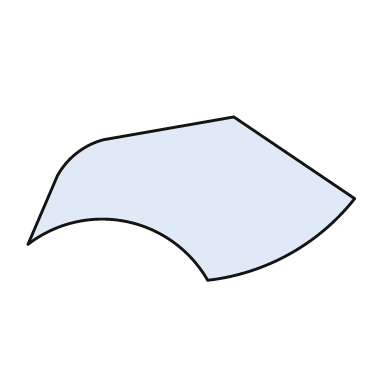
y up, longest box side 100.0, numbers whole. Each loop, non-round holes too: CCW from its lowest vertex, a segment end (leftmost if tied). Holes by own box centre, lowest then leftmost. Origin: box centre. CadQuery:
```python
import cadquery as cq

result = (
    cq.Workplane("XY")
    .moveTo(5.0, -25.0)
    .threePointArc((30.0, -17.0), (50.0, 0.0))
    .lineTo(13.0, 25.0)
    .lineTo(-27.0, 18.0)
    .threePointArc((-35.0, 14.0), (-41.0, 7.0))
    .lineTo(-50.0, -14.0)
    .threePointArc((-20.0, -7.0), (5.0, -25.0))
    .close()
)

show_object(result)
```